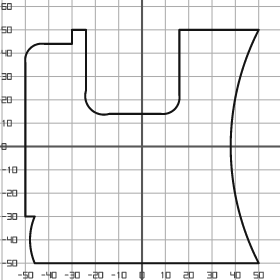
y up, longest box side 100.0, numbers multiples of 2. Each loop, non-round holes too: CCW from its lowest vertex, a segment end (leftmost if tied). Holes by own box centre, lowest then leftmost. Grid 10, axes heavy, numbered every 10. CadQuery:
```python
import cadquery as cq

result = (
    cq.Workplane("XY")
    .moveTo(-46.0, -50.0)
    .lineTo(50.0, -50.0)
    .threePointArc((38.0, 0.0), (50.0, 50.0))
    .lineTo(16.0, 50.0)
    .lineTo(16.0, 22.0)
    .threePointArc((14.0, 16.0), (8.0, 14.0))
    .lineTo(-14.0, 14.0)
    .threePointArc((-22.0, 16.0), (-24.0, 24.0))
    .lineTo(-24.0, 50.0)
    .lineTo(-30.0, 50.0)
    .lineTo(-30.0, 44.0)
    .lineTo(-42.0, 44.0)
    .threePointArc((-48.0, 42.0), (-50.0, 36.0))
    .lineTo(-50.0, -30.0)
    .lineTo(-46.0, -30.0)
    .threePointArc((-48.0, -40.0), (-46.0, -50.0))
    .close()
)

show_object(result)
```